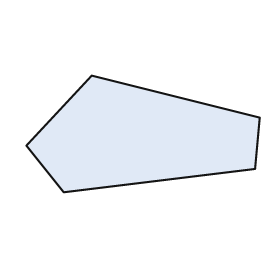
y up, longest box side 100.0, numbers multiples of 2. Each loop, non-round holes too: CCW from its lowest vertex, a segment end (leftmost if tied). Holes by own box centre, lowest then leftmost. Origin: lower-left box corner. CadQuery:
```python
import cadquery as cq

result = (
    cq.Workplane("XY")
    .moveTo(16.0, 0.0)
    .lineTo(98.0, 10.0)
    .lineTo(100.0, 32.0)
    .lineTo(28.0, 50.0)
    .lineTo(0.0, 20.0)
    .close()
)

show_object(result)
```